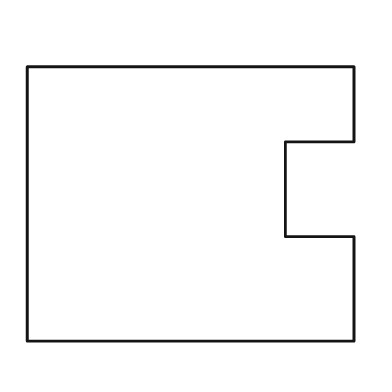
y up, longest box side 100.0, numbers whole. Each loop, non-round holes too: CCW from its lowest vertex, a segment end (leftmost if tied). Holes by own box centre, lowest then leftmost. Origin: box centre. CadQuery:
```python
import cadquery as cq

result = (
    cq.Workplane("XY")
    .moveTo(-50.0, -42.0)
    .lineTo(50.0, -42.0)
    .lineTo(50.0, -10.0)
    .lineTo(29.0, -10.0)
    .lineTo(29.0, 19.0)
    .lineTo(50.0, 19.0)
    .lineTo(50.0, 42.0)
    .lineTo(-50.0, 42.0)
    .close()
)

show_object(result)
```